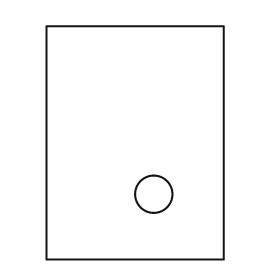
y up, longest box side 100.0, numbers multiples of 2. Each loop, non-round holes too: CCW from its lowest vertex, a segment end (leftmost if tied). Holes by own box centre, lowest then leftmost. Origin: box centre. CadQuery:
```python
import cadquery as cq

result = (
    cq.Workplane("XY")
    .moveTo(-38.0, -50.0)
    .lineTo(38.0, -50.0)
    .lineTo(38.0, 50.0)
    .lineTo(-38.0, 50.0)
    .close()
    .moveTo(8.0, -22.0)
    .circle(8.0)
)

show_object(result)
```